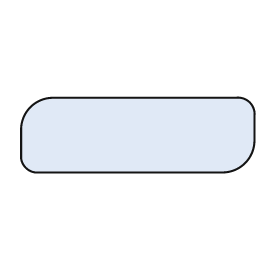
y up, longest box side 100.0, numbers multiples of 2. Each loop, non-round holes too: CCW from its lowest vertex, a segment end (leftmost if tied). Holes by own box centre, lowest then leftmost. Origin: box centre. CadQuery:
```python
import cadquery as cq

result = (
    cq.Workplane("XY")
    .moveTo(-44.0, -16.0)
    .lineTo(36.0, -16.0)
    .threePointArc((46.0, -12.0), (50.0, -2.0))
    .lineTo(50.0, 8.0)
    .threePointArc((48.0, 14.0), (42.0, 16.0))
    .lineTo(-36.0, 16.0)
    .threePointArc((-46.0, 12.0), (-50.0, 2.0))
    .lineTo(-50.0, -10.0)
    .threePointArc((-48.0, -14.0), (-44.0, -16.0))
    .close()
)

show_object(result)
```